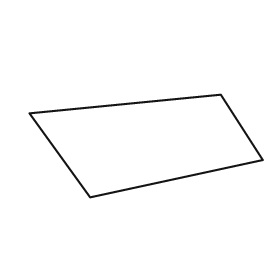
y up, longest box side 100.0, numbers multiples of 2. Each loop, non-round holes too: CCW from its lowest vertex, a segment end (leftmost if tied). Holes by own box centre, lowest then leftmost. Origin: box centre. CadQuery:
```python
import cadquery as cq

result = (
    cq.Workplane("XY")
    .moveTo(-24.0, -22.0)
    .lineTo(50.0, -6.0)
    .lineTo(32.0, 22.0)
    .lineTo(-50.0, 14.0)
    .close()
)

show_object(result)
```